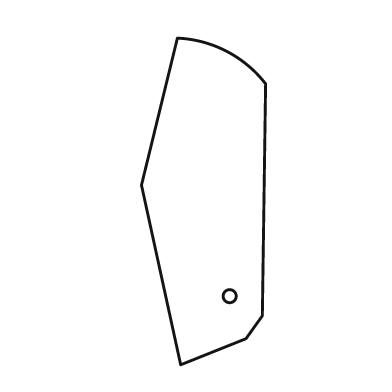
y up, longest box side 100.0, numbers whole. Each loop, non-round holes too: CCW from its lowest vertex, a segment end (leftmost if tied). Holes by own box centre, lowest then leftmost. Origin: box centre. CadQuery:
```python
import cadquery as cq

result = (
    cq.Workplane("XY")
    .moveTo(-7.0, -50.0)
    .lineTo(13.0, -42.0)
    .lineTo(18.0, -35.0)
    .lineTo(19.0, 36.0)
    .threePointArc((7.0, 46.0), (-8.0, 50.0))
    .lineTo(-19.0, 5.0)
    .close()
    .moveTo(8.0, -29.0)
    .circle(2.0)
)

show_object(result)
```